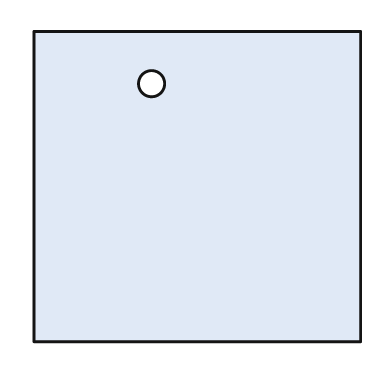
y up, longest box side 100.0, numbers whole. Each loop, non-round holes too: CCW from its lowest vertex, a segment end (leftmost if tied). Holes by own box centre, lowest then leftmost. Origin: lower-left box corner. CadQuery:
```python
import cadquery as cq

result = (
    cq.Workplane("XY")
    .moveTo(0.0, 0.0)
    .lineTo(100.0, 0.0)
    .lineTo(100.0, 95.0)
    .lineTo(0.0, 95.0)
    .close()
    .moveTo(36.0, 79.0)
    .circle(4.0)
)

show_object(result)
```